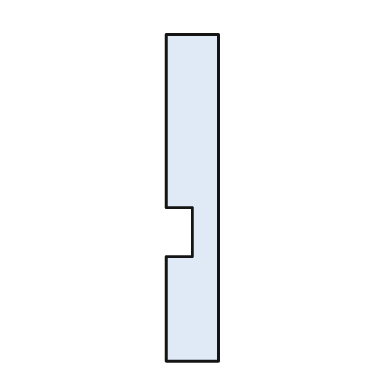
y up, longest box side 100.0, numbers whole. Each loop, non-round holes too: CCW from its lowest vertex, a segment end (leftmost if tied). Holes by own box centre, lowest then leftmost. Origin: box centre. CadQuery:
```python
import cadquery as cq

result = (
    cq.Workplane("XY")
    .moveTo(-8.0, -50.0)
    .lineTo(8.0, -50.0)
    .lineTo(8.0, 50.0)
    .lineTo(-8.0, 50.0)
    .lineTo(-8.0, -3.0)
    .lineTo(0.0, -3.0)
    .lineTo(0.0, -18.0)
    .lineTo(-8.0, -18.0)
    .close()
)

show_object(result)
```